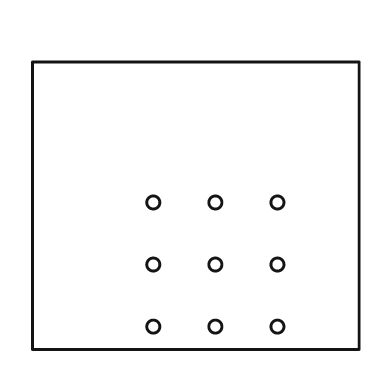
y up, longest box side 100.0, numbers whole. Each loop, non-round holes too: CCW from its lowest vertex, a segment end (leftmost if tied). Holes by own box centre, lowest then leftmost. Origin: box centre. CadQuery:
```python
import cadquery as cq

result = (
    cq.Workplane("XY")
    .moveTo(-50.0, -44.0)
    .lineTo(50.0, -44.0)
    .lineTo(50.0, 44.0)
    .lineTo(-50.0, 44.0)
    .close()
    .moveTo(-13.0, -37.0)
    .circle(2.0)
    .moveTo(6.0, -37.0)
    .circle(2.0)
    .moveTo(25.0, -37.0)
    .circle(2.0)
    .moveTo(-13.0, -18.0)
    .circle(2.0)
    .moveTo(6.0, -18.0)
    .circle(2.0)
    .moveTo(25.0, -18.0)
    .circle(2.0)
    .moveTo(-13.0, 1.0)
    .circle(2.0)
    .moveTo(6.0, 1.0)
    .circle(2.0)
    .moveTo(25.0, 1.0)
    .circle(2.0)
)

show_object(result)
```